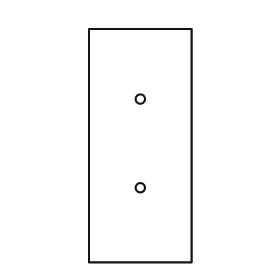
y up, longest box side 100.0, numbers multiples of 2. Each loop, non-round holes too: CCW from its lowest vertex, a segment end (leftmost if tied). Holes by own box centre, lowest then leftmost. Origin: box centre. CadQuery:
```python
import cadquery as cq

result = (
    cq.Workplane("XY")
    .moveTo(-22.0, -50.0)
    .lineTo(22.0, -50.0)
    .lineTo(22.0, 50.0)
    .lineTo(-22.0, 50.0)
    .close()
    .moveTo(0.0, -18.0)
    .circle(2.0)
    .moveTo(0.0, 20.0)
    .circle(2.0)
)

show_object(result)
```